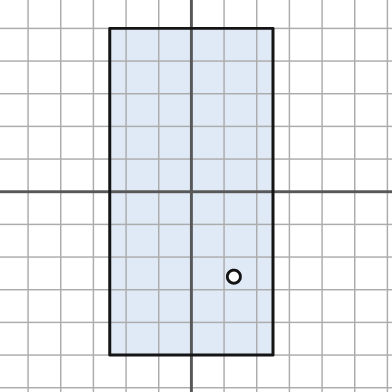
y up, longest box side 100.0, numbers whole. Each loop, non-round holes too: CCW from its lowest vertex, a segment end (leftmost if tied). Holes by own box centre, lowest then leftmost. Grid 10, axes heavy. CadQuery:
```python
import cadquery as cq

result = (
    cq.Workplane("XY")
    .moveTo(-25.0, -50.0)
    .lineTo(25.0, -50.0)
    .lineTo(25.0, 50.0)
    .lineTo(-25.0, 50.0)
    .close()
    .moveTo(13.0, -26.0)
    .circle(2.0)
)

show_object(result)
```